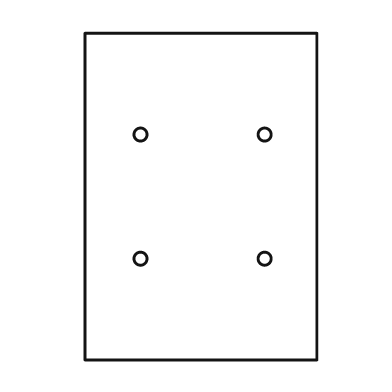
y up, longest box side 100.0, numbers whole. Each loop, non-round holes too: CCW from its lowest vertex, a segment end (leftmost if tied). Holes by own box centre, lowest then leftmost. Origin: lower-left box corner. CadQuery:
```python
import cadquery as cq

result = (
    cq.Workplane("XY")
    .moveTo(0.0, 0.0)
    .lineTo(71.0, 0.0)
    .lineTo(71.0, 100.0)
    .lineTo(0.0, 100.0)
    .close()
    .moveTo(17.0, 31.0)
    .circle(2.0)
    .moveTo(55.0, 31.0)
    .circle(2.0)
    .moveTo(17.0, 69.0)
    .circle(2.0)
    .moveTo(55.0, 69.0)
    .circle(2.0)
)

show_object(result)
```